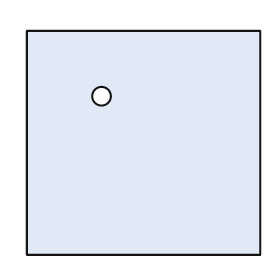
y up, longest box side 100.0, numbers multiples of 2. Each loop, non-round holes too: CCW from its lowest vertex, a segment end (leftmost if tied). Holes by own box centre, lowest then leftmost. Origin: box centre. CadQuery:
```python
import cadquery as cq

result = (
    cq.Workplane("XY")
    .moveTo(-50.0, -48.0)
    .lineTo(50.0, -48.0)
    .lineTo(50.0, 48.0)
    .lineTo(-50.0, 48.0)
    .close()
    .moveTo(-18.0, 20.0)
    .circle(4.0)
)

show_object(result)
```